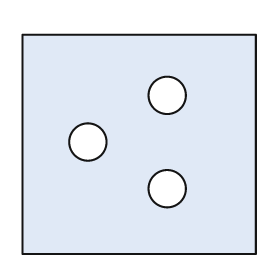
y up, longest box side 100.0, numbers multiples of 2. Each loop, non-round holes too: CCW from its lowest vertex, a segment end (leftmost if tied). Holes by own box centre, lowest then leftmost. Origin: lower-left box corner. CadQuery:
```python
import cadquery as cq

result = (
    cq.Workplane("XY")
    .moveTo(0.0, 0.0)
    .lineTo(100.0, 0.0)
    .lineTo(100.0, 94.0)
    .lineTo(0.0, 94.0)
    .close()
    .moveTo(62.0, 28.0)
    .circle(8.0)
    .moveTo(28.0, 48.0)
    .circle(8.0)
    .moveTo(62.0, 68.0)
    .circle(8.0)
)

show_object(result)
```